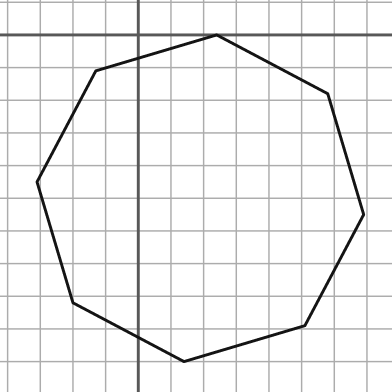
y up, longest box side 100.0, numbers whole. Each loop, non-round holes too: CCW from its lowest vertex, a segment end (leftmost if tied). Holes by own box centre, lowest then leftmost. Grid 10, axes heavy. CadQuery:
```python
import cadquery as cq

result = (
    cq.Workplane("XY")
    .moveTo(14.0, -100.0)
    .lineTo(51.0, -89.0)
    .lineTo(69.0, -55.0)
    .lineTo(58.0, -18.0)
    .lineTo(24.0, 0.0)
    .lineTo(-13.0, -11.0)
    .lineTo(-31.0, -45.0)
    .lineTo(-20.0, -82.0)
    .close()
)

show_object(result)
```